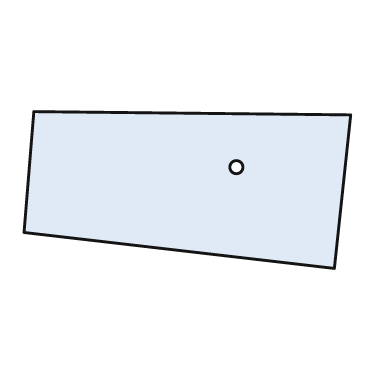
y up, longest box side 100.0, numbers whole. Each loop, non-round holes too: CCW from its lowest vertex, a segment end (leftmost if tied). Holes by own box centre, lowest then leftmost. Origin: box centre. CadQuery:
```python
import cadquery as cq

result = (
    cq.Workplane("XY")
    .moveTo(45.0, -24.0)
    .lineTo(50.0, 23.0)
    .lineTo(-47.0, 24.0)
    .lineTo(-50.0, -13.0)
    .close()
    .moveTo(15.0, 7.0)
    .circle(2.0)
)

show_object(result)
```